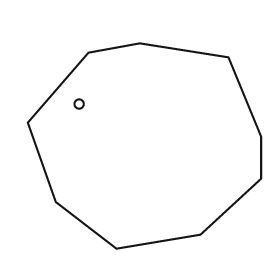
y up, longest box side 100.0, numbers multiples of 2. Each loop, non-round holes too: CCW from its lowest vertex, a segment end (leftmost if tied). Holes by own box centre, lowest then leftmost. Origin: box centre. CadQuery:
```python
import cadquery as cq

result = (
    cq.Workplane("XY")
    .moveTo(-12.0, -44.0)
    .lineTo(24.0, -38.0)
    .lineTo(50.0, -14.0)
    .lineTo(50.0, 4.0)
    .lineTo(36.0, 38.0)
    .lineTo(-2.0, 44.0)
    .lineTo(-24.0, 40.0)
    .lineTo(-50.0, 10.0)
    .lineTo(-38.0, -24.0)
    .close()
    .moveTo(-28.0, 18.0)
    .circle(2.0)
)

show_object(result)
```